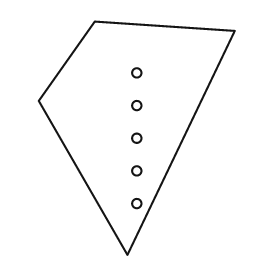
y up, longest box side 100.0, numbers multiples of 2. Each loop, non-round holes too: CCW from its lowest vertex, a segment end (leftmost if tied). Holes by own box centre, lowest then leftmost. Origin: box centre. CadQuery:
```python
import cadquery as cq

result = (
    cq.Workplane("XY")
    .moveTo(-4.0, -50.0)
    .lineTo(42.0, 46.0)
    .lineTo(-18.0, 50.0)
    .lineTo(-42.0, 16.0)
    .close()
    .moveTo(0.0, -28.0)
    .circle(2.0)
    .moveTo(0.0, -14.0)
    .circle(2.0)
    .moveTo(0.0, 0.0)
    .circle(2.0)
    .moveTo(0.0, 14.0)
    .circle(2.0)
    .moveTo(0.0, 28.0)
    .circle(2.0)
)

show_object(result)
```